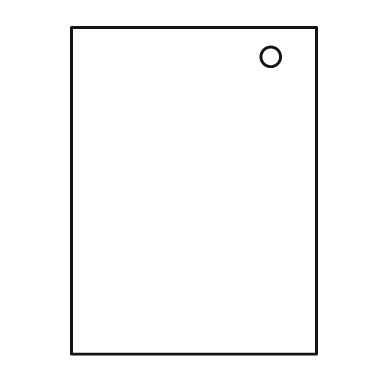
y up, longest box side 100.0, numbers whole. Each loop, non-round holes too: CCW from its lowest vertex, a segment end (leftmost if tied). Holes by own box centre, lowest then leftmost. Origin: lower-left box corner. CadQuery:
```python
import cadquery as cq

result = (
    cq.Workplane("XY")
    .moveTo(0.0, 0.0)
    .lineTo(75.0, 0.0)
    .lineTo(75.0, 100.0)
    .lineTo(0.0, 100.0)
    .close()
    .moveTo(61.0, 91.0)
    .circle(3.0)
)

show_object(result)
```